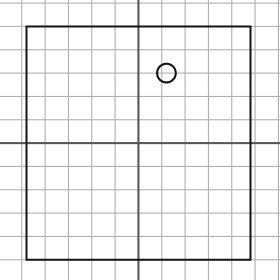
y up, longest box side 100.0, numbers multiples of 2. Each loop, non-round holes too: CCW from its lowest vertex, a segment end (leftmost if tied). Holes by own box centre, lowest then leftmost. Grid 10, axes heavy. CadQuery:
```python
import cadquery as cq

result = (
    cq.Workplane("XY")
    .moveTo(-48.0, -50.0)
    .lineTo(48.0, -50.0)
    .lineTo(48.0, 50.0)
    .lineTo(-48.0, 50.0)
    .close()
    .moveTo(12.0, 30.0)
    .circle(4.0)
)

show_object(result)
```